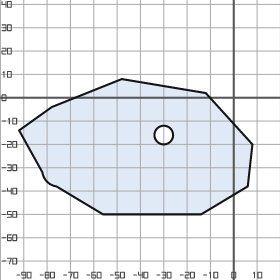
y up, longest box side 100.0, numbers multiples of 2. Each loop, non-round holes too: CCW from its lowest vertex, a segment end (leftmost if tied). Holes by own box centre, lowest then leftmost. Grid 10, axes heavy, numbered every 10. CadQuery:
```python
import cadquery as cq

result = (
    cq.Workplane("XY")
    .moveTo(-56.0, -50.0)
    .lineTo(-14.0, -50.0)
    .lineTo(6.0, -38.0)
    .lineTo(8.0, -20.0)
    .lineTo(-12.0, 2.0)
    .lineTo(-48.0, 8.0)
    .lineTo(-78.0, -4.0)
    .lineTo(-92.0, -14.0)
    .lineTo(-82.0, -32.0)
    .threePointArc((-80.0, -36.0), (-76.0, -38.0))
    .close()
    .moveTo(-30.0, -16.0)
    .circle(4.0)
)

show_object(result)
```